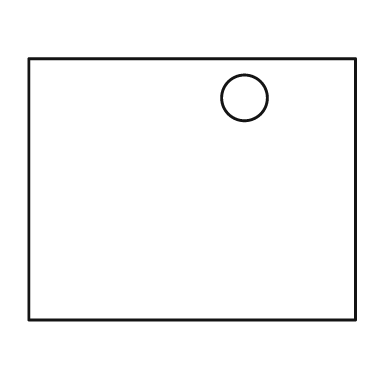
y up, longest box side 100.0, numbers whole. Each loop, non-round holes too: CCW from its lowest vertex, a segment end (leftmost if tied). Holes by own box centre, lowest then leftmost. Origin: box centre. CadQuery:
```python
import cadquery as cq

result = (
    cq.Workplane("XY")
    .moveTo(-50.0, -40.0)
    .lineTo(50.0, -40.0)
    .lineTo(50.0, 40.0)
    .lineTo(-50.0, 40.0)
    .close()
    .moveTo(16.0, 28.0)
    .circle(7.0)
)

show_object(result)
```